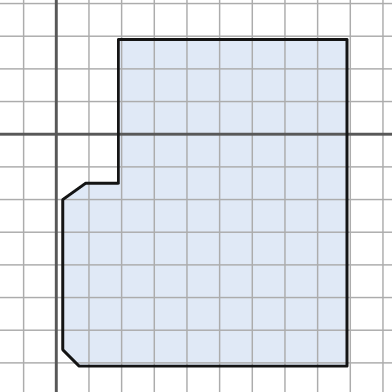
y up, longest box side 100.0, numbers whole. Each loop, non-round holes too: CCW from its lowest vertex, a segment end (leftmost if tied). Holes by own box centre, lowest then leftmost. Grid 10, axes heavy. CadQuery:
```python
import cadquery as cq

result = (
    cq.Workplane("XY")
    .moveTo(7.0, -71.0)
    .lineTo(89.0, -71.0)
    .lineTo(89.0, 29.0)
    .lineTo(19.0, 29.0)
    .lineTo(19.0, -15.0)
    .lineTo(9.0, -15.0)
    .lineTo(2.0, -20.0)
    .lineTo(2.0, -66.0)
    .close()
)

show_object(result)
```